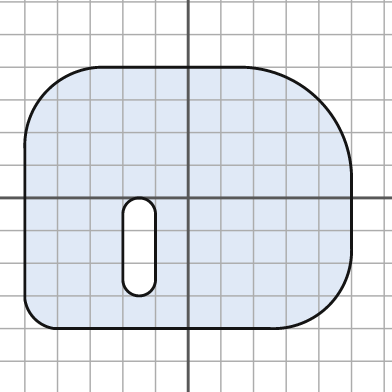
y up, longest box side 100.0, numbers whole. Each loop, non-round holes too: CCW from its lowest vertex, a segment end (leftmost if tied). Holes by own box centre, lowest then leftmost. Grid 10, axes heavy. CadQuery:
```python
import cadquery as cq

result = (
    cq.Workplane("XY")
    .moveTo(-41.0, -40.0)
    .lineTo(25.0, -40.0)
    .threePointArc((43.0, -33.0), (50.0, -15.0))
    .lineTo(50.0, 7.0)
    .threePointArc((40.0, 30.0), (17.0, 40.0))
    .lineTo(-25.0, 40.0)
    .threePointArc((-43.0, 33.0), (-50.0, 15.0))
    .lineTo(-50.0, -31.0)
    .threePointArc((-47.0, -37.0), (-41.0, -40.0))
    .close()
    .moveTo(-20.0, -25.0)
    .threePointArc((-15.0, -30.0), (-10.0, -25.0))
    .lineTo(-10.0, -5.0)
    .threePointArc((-15.0, 0.0), (-20.0, -5.0))
    .close()
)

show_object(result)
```